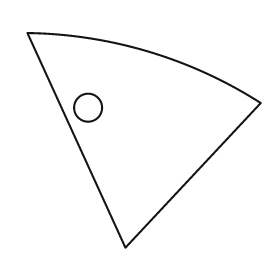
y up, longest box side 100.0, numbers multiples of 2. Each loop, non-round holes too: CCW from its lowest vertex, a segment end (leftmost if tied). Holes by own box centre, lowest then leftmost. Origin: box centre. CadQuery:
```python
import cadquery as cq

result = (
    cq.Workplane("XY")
    .moveTo(-8.0, -46.0)
    .lineTo(50.0, 16.0)
    .threePointArc((2.0, 38.0), (-50.0, 46.0))
    .close()
    .moveTo(-24.0, 14.0)
    .circle(6.0)
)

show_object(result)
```